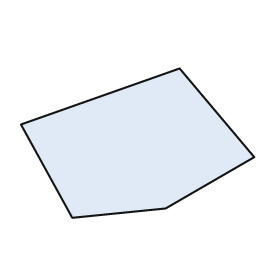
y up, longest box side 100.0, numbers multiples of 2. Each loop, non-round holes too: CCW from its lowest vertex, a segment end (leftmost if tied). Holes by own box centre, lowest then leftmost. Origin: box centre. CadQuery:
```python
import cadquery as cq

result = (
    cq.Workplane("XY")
    .moveTo(-28.0, -32.0)
    .lineTo(12.0, -28.0)
    .lineTo(50.0, -6.0)
    .lineTo(18.0, 32.0)
    .lineTo(-50.0, 8.0)
    .close()
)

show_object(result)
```